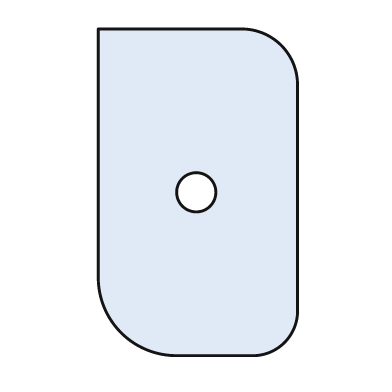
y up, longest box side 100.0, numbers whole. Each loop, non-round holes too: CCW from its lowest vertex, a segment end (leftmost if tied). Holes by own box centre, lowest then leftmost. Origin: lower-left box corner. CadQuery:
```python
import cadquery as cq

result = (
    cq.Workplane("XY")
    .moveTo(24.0, 0.0)
    .lineTo(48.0, 0.0)
    .threePointArc((57.0, 4.0), (61.0, 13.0))
    .lineTo(61.0, 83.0)
    .threePointArc((56.0, 95.0), (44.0, 100.0))
    .lineTo(0.0, 100.0)
    .lineTo(0.0, 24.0)
    .threePointArc((7.0, 7.0), (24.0, 0.0))
    .close()
    .moveTo(30.0, 50.0)
    .circle(6.0)
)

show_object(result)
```